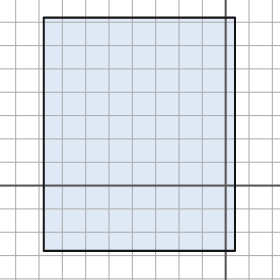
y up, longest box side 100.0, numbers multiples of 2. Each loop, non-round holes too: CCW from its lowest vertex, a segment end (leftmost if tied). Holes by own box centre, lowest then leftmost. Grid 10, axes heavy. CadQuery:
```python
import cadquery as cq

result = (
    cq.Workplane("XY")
    .moveTo(-78.0, -28.0)
    .lineTo(4.0, -28.0)
    .lineTo(4.0, 72.0)
    .lineTo(-78.0, 72.0)
    .close()
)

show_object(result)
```